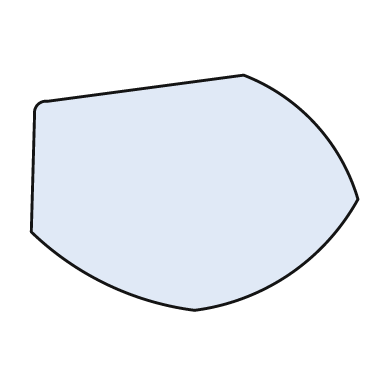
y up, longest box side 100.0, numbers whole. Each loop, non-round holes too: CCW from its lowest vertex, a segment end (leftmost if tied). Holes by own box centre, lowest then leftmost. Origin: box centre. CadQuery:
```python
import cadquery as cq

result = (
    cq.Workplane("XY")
    .moveTo(0.0, -36.0)
    .threePointArc((29.0, -25.0), (50.0, -2.0))
    .threePointArc((37.0, 21.0), (15.0, 36.0))
    .lineTo(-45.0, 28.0)
    .threePointArc((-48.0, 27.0), (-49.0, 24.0))
    .lineTo(-50.0, -12.0)
    .threePointArc((-27.0, -28.0), (0.0, -36.0))
    .close()
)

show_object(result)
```